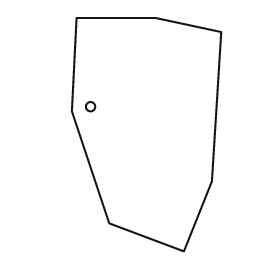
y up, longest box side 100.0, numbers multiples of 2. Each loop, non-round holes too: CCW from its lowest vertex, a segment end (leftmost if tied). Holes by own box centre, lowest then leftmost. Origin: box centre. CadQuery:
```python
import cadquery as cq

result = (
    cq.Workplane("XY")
    .moveTo(16.0, -50.0)
    .lineTo(28.0, -20.0)
    .lineTo(32.0, 44.0)
    .lineTo(4.0, 50.0)
    .lineTo(-30.0, 50.0)
    .lineTo(-32.0, 10.0)
    .lineTo(-16.0, -38.0)
    .close()
    .moveTo(-24.0, 12.0)
    .circle(2.0)
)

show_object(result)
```